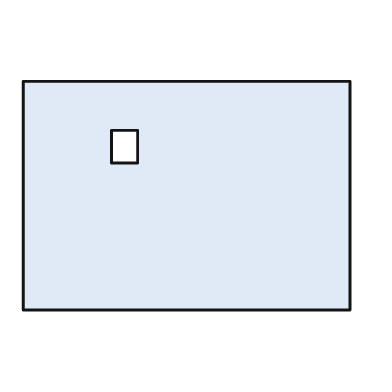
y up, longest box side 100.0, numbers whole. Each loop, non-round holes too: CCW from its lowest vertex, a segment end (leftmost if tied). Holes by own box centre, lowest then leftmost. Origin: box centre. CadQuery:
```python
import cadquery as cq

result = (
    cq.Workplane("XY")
    .moveTo(-50.0, -35.0)
    .lineTo(50.0, -35.0)
    .lineTo(50.0, 35.0)
    .lineTo(-50.0, 35.0)
    .close()
    .moveTo(-23.0, 10.0)
    .lineTo(-15.0, 10.0)
    .lineTo(-15.0, 20.0)
    .lineTo(-23.0, 20.0)
    .close()
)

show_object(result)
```